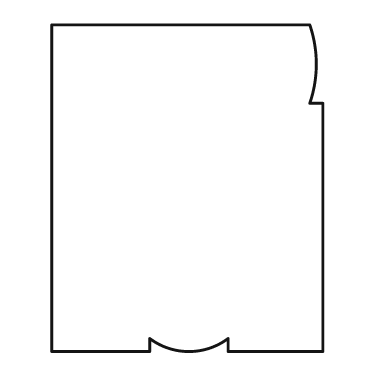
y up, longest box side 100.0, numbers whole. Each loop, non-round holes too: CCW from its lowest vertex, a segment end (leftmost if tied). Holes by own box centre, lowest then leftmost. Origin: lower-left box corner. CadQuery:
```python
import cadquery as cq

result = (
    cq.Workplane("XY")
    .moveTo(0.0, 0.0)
    .lineTo(30.0, 0.0)
    .lineTo(30.0, 4.0)
    .threePointArc((42.0, 0.0), (54.0, 4.0))
    .lineTo(54.0, 0.0)
    .lineTo(83.0, 0.0)
    .lineTo(83.0, 76.0)
    .lineTo(79.0, 76.0)
    .threePointArc((81.0, 88.0), (79.0, 100.0))
    .lineTo(0.0, 100.0)
    .close()
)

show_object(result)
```